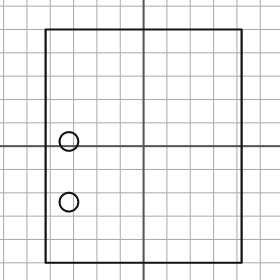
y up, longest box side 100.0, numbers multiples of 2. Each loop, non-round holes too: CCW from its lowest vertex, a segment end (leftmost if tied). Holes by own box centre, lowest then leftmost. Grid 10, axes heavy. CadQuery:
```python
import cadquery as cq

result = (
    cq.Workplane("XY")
    .moveTo(-42.0, -50.0)
    .lineTo(42.0, -50.0)
    .lineTo(42.0, 50.0)
    .lineTo(-42.0, 50.0)
    .close()
    .moveTo(-32.0, -24.0)
    .circle(4.0)
    .moveTo(-32.0, 2.0)
    .circle(4.0)
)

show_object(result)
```